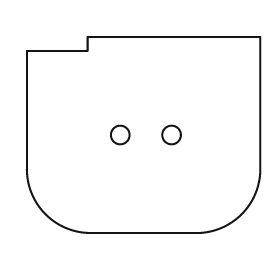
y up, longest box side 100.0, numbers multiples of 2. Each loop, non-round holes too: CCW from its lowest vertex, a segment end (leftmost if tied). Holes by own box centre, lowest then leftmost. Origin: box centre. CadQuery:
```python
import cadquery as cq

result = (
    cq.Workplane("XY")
    .moveTo(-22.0, -42.0)
    .lineTo(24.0, -42.0)
    .threePointArc((42.0, -34.0), (50.0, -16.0))
    .lineTo(50.0, 42.0)
    .lineTo(-24.0, 42.0)
    .lineTo(-24.0, 36.0)
    .lineTo(-50.0, 36.0)
    .lineTo(-50.0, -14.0)
    .threePointArc((-42.0, -34.0), (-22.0, -42.0))
    .close()
    .moveTo(-10.0, 0.0)
    .circle(4.0)
    .moveTo(12.0, 0.0)
    .circle(4.0)
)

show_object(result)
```